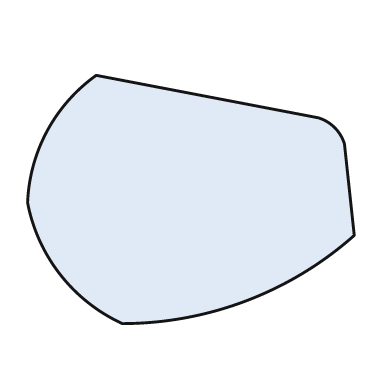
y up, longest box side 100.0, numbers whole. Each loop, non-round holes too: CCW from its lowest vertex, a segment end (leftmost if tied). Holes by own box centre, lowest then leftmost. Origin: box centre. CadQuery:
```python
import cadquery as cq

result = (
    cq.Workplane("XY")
    .moveTo(-21.0, -38.0)
    .threePointArc((17.0, -31.0), (50.0, -11.0))
    .lineTo(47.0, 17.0)
    .threePointArc((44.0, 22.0), (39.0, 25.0))
    .lineTo(-29.0, 38.0)
    .threePointArc((-44.0, 21.0), (-50.0, -1.0))
    .threePointArc((-40.0, -23.0), (-21.0, -38.0))
    .close()
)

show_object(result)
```